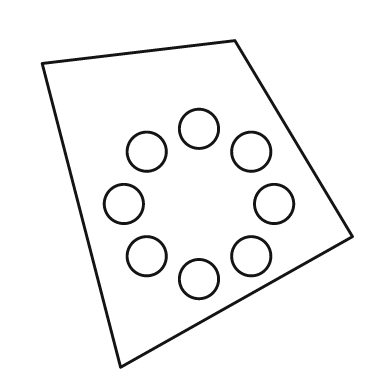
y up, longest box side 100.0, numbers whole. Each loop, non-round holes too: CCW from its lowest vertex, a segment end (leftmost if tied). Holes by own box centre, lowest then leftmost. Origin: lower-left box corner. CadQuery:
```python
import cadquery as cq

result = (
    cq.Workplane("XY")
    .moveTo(24.0, 0.0)
    .lineTo(95.0, 40.0)
    .lineTo(59.0, 100.0)
    .lineTo(0.0, 93.0)
    .close()
    .moveTo(48.0, 27.0)
    .circle(6.0)
    .moveTo(32.0, 34.0)
    .circle(6.0)
    .moveTo(64.0, 34.0)
    .circle(6.0)
    .moveTo(25.0, 50.0)
    .circle(6.0)
    .moveTo(71.0, 50.0)
    .circle(6.0)
    .moveTo(32.0, 66.0)
    .circle(6.0)
    .moveTo(64.0, 66.0)
    .circle(6.0)
    .moveTo(48.0, 73.0)
    .circle(6.0)
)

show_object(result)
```